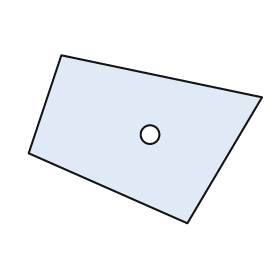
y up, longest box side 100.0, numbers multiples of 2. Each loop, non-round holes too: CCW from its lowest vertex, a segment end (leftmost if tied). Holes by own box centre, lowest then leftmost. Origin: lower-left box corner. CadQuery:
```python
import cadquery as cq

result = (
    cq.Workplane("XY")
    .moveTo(68.0, 0.0)
    .lineTo(100.0, 54.0)
    .lineTo(14.0, 72.0)
    .lineTo(0.0, 30.0)
    .close()
    .moveTo(52.0, 38.0)
    .circle(4.0)
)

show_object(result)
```